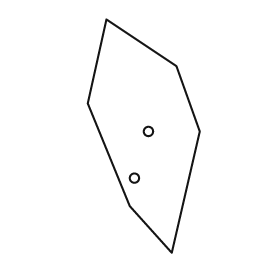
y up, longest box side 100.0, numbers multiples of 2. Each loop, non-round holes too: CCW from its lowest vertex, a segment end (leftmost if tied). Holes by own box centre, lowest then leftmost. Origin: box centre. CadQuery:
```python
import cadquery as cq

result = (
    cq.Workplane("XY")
    .moveTo(12.0, -50.0)
    .lineTo(24.0, 2.0)
    .lineTo(14.0, 30.0)
    .lineTo(-16.0, 50.0)
    .lineTo(-24.0, 14.0)
    .lineTo(-6.0, -30.0)
    .close()
    .moveTo(-4.0, -18.0)
    .circle(2.0)
    .moveTo(2.0, 2.0)
    .circle(2.0)
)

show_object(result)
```